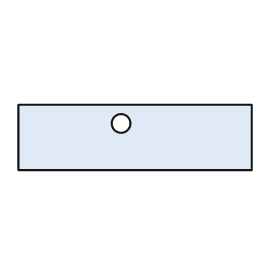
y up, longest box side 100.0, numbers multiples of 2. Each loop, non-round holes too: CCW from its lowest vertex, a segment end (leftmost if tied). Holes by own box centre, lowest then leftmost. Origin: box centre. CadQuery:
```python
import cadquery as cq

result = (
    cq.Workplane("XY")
    .moveTo(-50.0, -14.0)
    .lineTo(50.0, -14.0)
    .lineTo(50.0, 14.0)
    .lineTo(-50.0, 14.0)
    .close()
    .moveTo(-6.0, 6.0)
    .circle(4.0)
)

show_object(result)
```